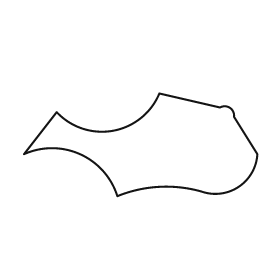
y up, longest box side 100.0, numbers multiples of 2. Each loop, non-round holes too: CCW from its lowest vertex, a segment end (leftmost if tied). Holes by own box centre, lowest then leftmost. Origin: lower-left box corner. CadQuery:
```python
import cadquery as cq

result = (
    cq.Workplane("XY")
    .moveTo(40.0, 0.0)
    .threePointArc((58.0, 4.0), (76.0, 2.0))
    .threePointArc((92.0, 4.0), (100.0, 18.0))
    .lineTo(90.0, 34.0)
    .threePointArc((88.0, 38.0), (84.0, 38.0))
    .lineTo(58.0, 44.0)
    .threePointArc((38.0, 28.0), (14.0, 36.0))
    .lineTo(0.0, 18.0)
    .threePointArc((24.0, 18.0), (40.0, 0.0))
    .close()
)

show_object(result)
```